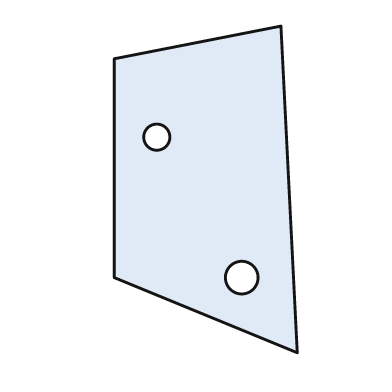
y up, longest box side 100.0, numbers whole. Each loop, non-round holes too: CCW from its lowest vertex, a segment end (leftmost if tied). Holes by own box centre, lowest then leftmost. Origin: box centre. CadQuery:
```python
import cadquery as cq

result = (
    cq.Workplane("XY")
    .moveTo(28.0, -50.0)
    .lineTo(23.0, 50.0)
    .lineTo(-28.0, 40.0)
    .lineTo(-28.0, -27.0)
    .close()
    .moveTo(11.0, -27.0)
    .circle(5.0)
    .moveTo(-15.0, 16.0)
    .circle(4.0)
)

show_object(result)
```